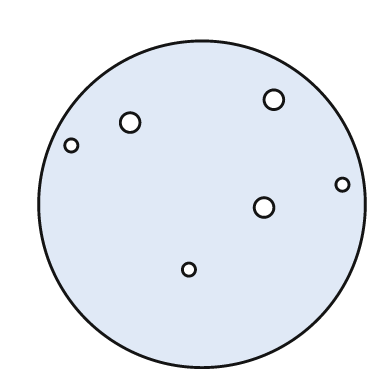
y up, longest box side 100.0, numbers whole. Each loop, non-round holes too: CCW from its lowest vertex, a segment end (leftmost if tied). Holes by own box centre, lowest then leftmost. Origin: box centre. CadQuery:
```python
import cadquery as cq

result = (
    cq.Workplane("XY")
    .moveTo(0.0, 0.0)
    .circle(50.0)
    .moveTo(-4.0, -20.0)
    .circle(2.0)
    .moveTo(19.0, -1.0)
    .circle(3.0)
    .moveTo(43.0, 6.0)
    .circle(2.0)
    .moveTo(-40.0, 18.0)
    .circle(2.0)
    .moveTo(-22.0, 25.0)
    .circle(3.0)
    .moveTo(22.0, 32.0)
    .circle(3.0)
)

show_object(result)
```